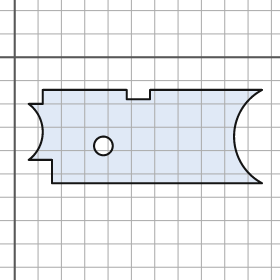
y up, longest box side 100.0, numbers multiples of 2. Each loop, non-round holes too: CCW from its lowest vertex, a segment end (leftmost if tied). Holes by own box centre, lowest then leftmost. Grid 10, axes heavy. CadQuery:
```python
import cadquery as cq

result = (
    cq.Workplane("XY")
    .moveTo(16.0, -54.0)
    .lineTo(106.0, -54.0)
    .threePointArc((94.0, -34.0), (106.0, -14.0))
    .lineTo(58.0, -14.0)
    .lineTo(58.0, -18.0)
    .lineTo(48.0, -18.0)
    .lineTo(48.0, -14.0)
    .lineTo(12.0, -14.0)
    .lineTo(12.0, -20.0)
    .lineTo(6.0, -20.0)
    .threePointArc((12.0, -32.0), (6.0, -44.0))
    .lineTo(16.0, -44.0)
    .close()
    .moveTo(38.0, -38.0)
    .circle(4.0)
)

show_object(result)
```